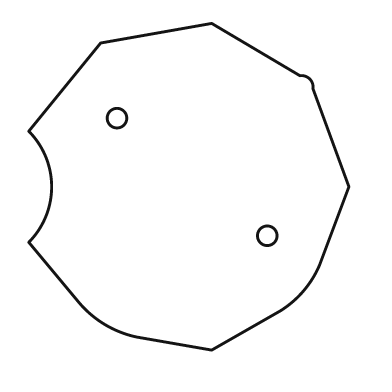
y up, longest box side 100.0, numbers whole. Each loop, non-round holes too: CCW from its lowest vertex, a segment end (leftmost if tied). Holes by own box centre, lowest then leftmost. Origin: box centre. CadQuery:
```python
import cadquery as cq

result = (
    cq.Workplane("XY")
    .moveTo(7.0, -50.0)
    .lineTo(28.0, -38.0)
    .threePointArc((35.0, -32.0), (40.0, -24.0))
    .lineTo(49.0, 0.0)
    .lineTo(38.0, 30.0)
    .threePointArc((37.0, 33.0), (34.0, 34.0))
    .lineTo(7.0, 50.0)
    .lineTo(-27.0, 44.0)
    .lineTo(-49.0, 17.0)
    .threePointArc((-42.0, 0.0), (-49.0, -17.0))
    .lineTo(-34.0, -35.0)
    .threePointArc((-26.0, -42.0), (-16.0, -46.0))
    .close()
    .moveTo(24.0, -15.0)
    .circle(3.0)
    .moveTo(-22.0, 21.0)
    .circle(3.0)
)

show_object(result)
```